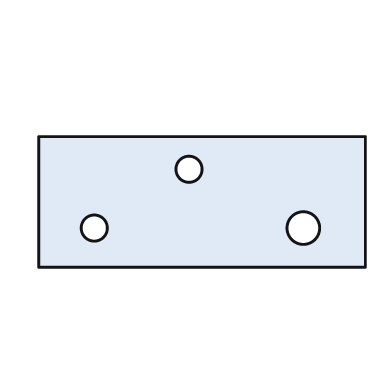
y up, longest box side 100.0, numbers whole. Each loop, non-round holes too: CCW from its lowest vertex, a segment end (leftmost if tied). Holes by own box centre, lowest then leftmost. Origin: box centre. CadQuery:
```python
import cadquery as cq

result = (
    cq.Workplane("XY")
    .moveTo(-50.0, -20.0)
    .lineTo(50.0, -20.0)
    .lineTo(50.0, 20.0)
    .lineTo(-50.0, 20.0)
    .close()
    .moveTo(-33.0, -8.0)
    .circle(4.0)
    .moveTo(31.0, -8.0)
    .circle(5.0)
    .moveTo(-4.0, 10.0)
    .circle(4.0)
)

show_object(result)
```